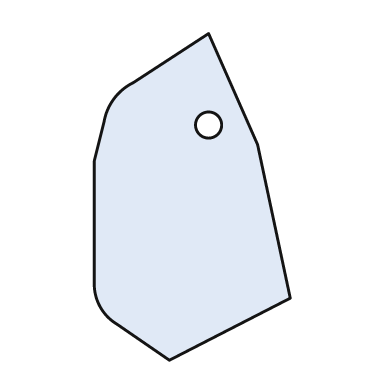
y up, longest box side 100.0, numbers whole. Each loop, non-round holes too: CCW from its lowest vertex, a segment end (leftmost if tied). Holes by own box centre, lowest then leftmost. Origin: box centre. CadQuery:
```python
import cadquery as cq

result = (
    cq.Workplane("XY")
    .moveTo(-7.0, -50.0)
    .lineTo(30.0, -31.0)
    .lineTo(20.0, 16.0)
    .lineTo(5.0, 50.0)
    .lineTo(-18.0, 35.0)
    .threePointArc((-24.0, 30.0), (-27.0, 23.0))
    .lineTo(-30.0, 11.0)
    .lineTo(-30.0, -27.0)
    .threePointArc((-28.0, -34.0), (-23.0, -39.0))
    .close()
    .moveTo(5.0, 22.0)
    .circle(4.0)
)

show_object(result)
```